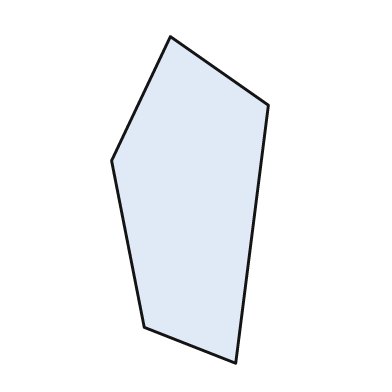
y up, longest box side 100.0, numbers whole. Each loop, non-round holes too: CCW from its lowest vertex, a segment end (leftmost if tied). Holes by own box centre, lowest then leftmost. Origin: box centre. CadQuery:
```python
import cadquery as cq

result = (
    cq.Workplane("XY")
    .moveTo(14.0, -50.0)
    .lineTo(24.0, 29.0)
    .lineTo(-6.0, 50.0)
    .lineTo(-24.0, 12.0)
    .lineTo(-14.0, -39.0)
    .close()
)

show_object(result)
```